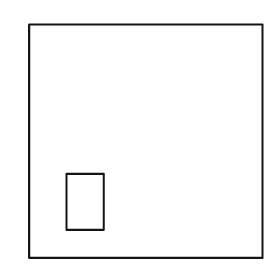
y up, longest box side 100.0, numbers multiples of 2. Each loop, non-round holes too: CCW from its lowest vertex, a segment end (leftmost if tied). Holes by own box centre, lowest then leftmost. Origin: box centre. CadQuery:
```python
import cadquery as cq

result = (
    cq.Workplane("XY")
    .moveTo(-50.0, -50.0)
    .lineTo(50.0, -50.0)
    .lineTo(50.0, 50.0)
    .lineTo(-50.0, 50.0)
    .close()
    .moveTo(-34.0, -38.0)
    .lineTo(-18.0, -38.0)
    .lineTo(-18.0, -14.0)
    .lineTo(-34.0, -14.0)
    .close()
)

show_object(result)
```